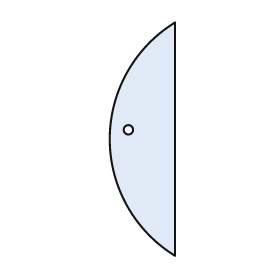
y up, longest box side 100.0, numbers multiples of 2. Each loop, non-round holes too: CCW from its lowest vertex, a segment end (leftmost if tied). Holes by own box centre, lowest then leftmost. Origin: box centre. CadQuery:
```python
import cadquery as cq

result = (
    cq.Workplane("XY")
    .moveTo(14.0, -50.0)
    .lineTo(14.0, 50.0)
    .threePointArc((-14.0, 0.0), (14.0, -50.0))
    .close()
    .moveTo(-6.0, 4.0)
    .circle(2.0)
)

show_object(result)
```